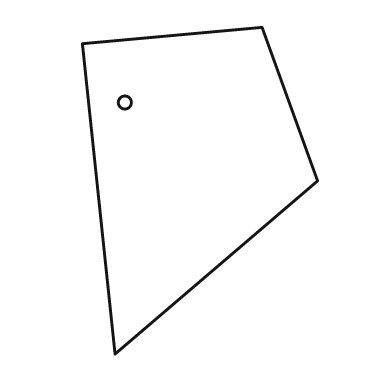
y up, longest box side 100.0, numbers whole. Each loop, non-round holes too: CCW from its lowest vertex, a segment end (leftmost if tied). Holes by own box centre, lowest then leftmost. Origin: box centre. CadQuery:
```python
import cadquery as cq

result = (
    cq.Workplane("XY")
    .moveTo(-26.0, -50.0)
    .lineTo(36.0, 3.0)
    .lineTo(19.0, 50.0)
    .lineTo(-36.0, 45.0)
    .close()
    .moveTo(-23.0, 27.0)
    .circle(2.0)
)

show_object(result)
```